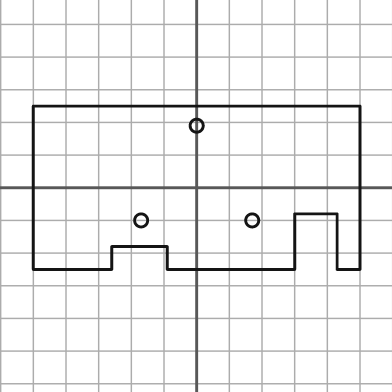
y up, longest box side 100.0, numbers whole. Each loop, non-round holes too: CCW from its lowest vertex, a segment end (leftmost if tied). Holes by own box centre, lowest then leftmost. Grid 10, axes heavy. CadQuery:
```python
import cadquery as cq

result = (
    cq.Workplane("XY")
    .moveTo(-50.0, -25.0)
    .lineTo(-26.0, -25.0)
    .lineTo(-26.0, -18.0)
    .lineTo(-9.0, -18.0)
    .lineTo(-9.0, -25.0)
    .lineTo(30.0, -25.0)
    .lineTo(30.0, -8.0)
    .lineTo(43.0, -8.0)
    .lineTo(43.0, -25.0)
    .lineTo(50.0, -25.0)
    .lineTo(50.0, 25.0)
    .lineTo(-50.0, 25.0)
    .close()
    .moveTo(-17.0, -10.0)
    .circle(2.0)
    .moveTo(17.0, -10.0)
    .circle(2.0)
    .moveTo(0.0, 19.0)
    .circle(2.0)
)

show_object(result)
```